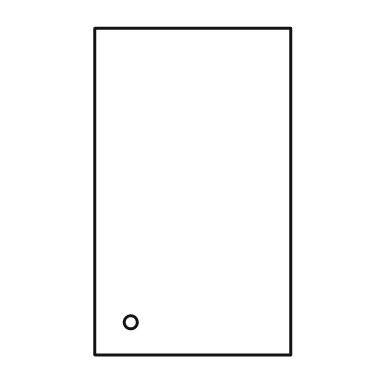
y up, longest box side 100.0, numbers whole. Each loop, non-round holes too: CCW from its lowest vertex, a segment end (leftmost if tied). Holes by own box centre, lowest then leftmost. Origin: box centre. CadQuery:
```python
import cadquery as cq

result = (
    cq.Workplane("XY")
    .moveTo(-30.0, -50.0)
    .lineTo(30.0, -50.0)
    .lineTo(30.0, 50.0)
    .lineTo(-30.0, 50.0)
    .close()
    .moveTo(-19.0, -40.0)
    .circle(2.0)
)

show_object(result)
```